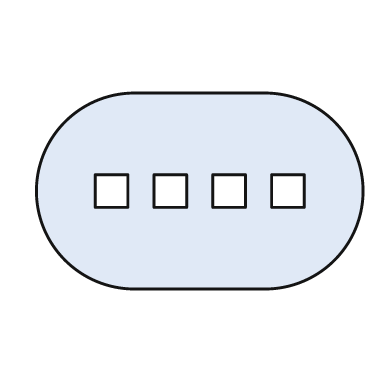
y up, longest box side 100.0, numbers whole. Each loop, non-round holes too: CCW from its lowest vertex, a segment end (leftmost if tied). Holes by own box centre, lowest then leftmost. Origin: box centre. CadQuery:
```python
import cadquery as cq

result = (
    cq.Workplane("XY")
    .moveTo(-20.0, -30.0)
    .lineTo(20.0, -30.0)
    .threePointArc((50.0, 0.0), (20.0, 30.0))
    .lineTo(-20.0, 30.0)
    .threePointArc((-50.0, 0.0), (-20.0, -30.0))
    .close()
    .moveTo(-32.0, -5.0)
    .lineTo(-22.0, -5.0)
    .lineTo(-22.0, 5.0)
    .lineTo(-32.0, 5.0)
    .close()
    .moveTo(-14.0, -5.0)
    .lineTo(-4.0, -5.0)
    .lineTo(-4.0, 5.0)
    .lineTo(-14.0, 5.0)
    .close()
    .moveTo(4.0, -5.0)
    .lineTo(14.0, -5.0)
    .lineTo(14.0, 5.0)
    .lineTo(4.0, 5.0)
    .close()
    .moveTo(22.0, -5.0)
    .lineTo(32.0, -5.0)
    .lineTo(32.0, 5.0)
    .lineTo(22.0, 5.0)
    .close()
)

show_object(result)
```